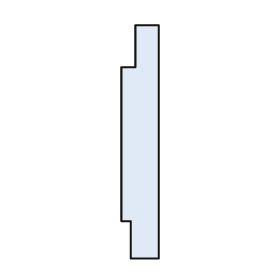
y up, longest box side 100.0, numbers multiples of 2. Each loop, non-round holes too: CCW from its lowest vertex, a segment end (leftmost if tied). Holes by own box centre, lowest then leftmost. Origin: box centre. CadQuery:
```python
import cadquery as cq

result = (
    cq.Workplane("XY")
    .moveTo(-4.0, -50.0)
    .lineTo(8.0, -50.0)
    .lineTo(8.0, 50.0)
    .lineTo(-2.0, 50.0)
    .lineTo(-2.0, 32.0)
    .lineTo(-8.0, 32.0)
    .lineTo(-8.0, -34.0)
    .lineTo(-4.0, -34.0)
    .close()
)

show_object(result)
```